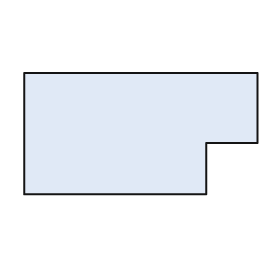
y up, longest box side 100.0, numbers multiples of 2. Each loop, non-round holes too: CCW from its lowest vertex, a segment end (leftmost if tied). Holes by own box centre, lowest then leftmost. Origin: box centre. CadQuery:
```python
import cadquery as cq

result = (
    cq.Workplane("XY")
    .moveTo(-50.0, -26.0)
    .lineTo(28.0, -26.0)
    .lineTo(28.0, -4.0)
    .lineTo(50.0, -4.0)
    .lineTo(50.0, 26.0)
    .lineTo(-50.0, 26.0)
    .close()
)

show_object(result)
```